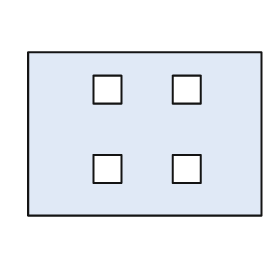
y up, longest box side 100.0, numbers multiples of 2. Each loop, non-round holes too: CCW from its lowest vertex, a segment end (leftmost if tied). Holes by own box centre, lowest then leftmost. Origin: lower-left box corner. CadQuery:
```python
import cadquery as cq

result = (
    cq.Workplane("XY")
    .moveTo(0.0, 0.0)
    .lineTo(100.0, 0.0)
    .lineTo(100.0, 70.0)
    .lineTo(0.0, 70.0)
    .close()
    .moveTo(28.0, 14.0)
    .lineTo(40.0, 14.0)
    .lineTo(40.0, 26.0)
    .lineTo(28.0, 26.0)
    .close()
    .moveTo(62.0, 14.0)
    .lineTo(74.0, 14.0)
    .lineTo(74.0, 26.0)
    .lineTo(62.0, 26.0)
    .close()
    .moveTo(28.0, 48.0)
    .lineTo(40.0, 48.0)
    .lineTo(40.0, 60.0)
    .lineTo(28.0, 60.0)
    .close()
    .moveTo(62.0, 48.0)
    .lineTo(74.0, 48.0)
    .lineTo(74.0, 60.0)
    .lineTo(62.0, 60.0)
    .close()
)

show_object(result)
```